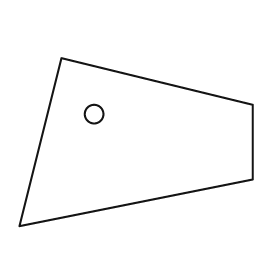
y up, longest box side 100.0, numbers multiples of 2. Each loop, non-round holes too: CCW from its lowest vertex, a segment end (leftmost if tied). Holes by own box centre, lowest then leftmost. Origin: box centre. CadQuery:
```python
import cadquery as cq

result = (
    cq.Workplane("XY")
    .moveTo(-50.0, -36.0)
    .lineTo(50.0, -16.0)
    .lineTo(50.0, 16.0)
    .lineTo(-32.0, 36.0)
    .close()
    .moveTo(-18.0, 12.0)
    .circle(4.0)
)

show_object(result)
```